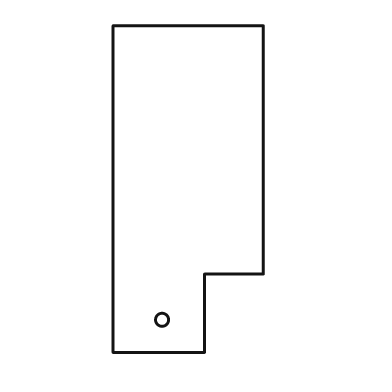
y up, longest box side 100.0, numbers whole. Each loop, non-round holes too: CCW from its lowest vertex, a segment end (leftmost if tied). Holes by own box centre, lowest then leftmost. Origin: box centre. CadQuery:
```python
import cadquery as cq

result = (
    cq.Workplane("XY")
    .moveTo(-23.0, -50.0)
    .lineTo(5.0, -50.0)
    .lineTo(5.0, -26.0)
    .lineTo(23.0, -26.0)
    .lineTo(23.0, 50.0)
    .lineTo(-23.0, 50.0)
    .close()
    .moveTo(-8.0, -40.0)
    .circle(2.0)
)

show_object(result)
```